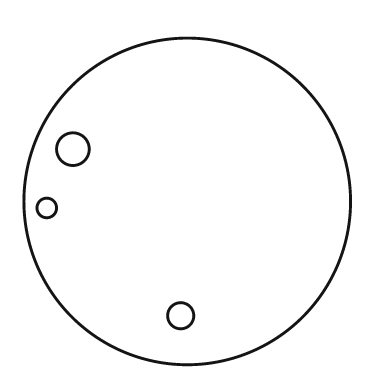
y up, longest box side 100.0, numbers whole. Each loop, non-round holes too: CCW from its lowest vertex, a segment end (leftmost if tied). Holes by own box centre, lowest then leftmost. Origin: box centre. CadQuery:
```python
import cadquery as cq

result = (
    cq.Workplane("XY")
    .moveTo(0.0, 0.0)
    .circle(50.0)
    .moveTo(-2.0, -35.0)
    .circle(4.0)
    .moveTo(-43.0, -2.0)
    .circle(3.0)
    .moveTo(-35.0, 16.0)
    .circle(5.0)
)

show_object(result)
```